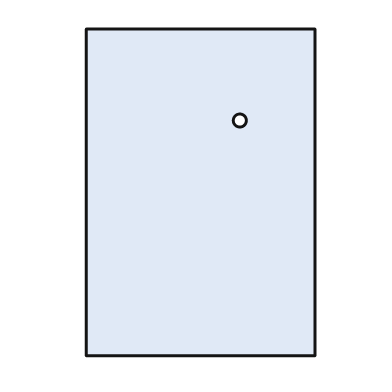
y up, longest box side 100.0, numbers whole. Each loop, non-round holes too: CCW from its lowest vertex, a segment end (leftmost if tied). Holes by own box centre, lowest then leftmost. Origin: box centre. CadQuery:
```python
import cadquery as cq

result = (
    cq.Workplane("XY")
    .moveTo(-35.0, -50.0)
    .lineTo(35.0, -50.0)
    .lineTo(35.0, 50.0)
    .lineTo(-35.0, 50.0)
    .close()
    .moveTo(12.0, 22.0)
    .circle(2.0)
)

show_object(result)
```